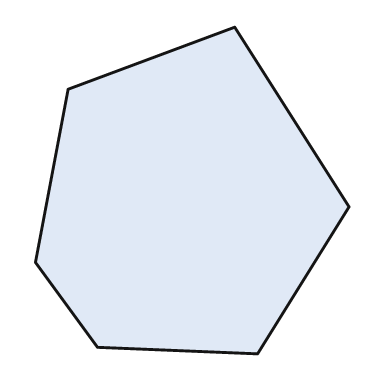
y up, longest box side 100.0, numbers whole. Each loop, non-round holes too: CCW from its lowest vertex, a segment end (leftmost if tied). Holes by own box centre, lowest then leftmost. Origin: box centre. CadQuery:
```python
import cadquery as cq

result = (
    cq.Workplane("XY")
    .moveTo(20.0, -50.0)
    .lineTo(48.0, -5.0)
    .lineTo(13.0, 50.0)
    .lineTo(-38.0, 31.0)
    .lineTo(-48.0, -22.0)
    .lineTo(-29.0, -48.0)
    .close()
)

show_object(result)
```